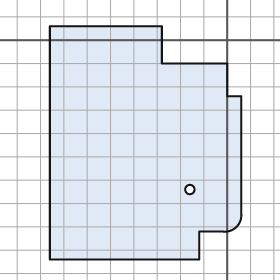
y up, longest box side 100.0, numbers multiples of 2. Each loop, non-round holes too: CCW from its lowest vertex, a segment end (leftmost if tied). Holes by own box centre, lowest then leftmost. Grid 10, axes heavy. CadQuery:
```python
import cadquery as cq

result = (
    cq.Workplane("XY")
    .moveTo(-76.0, -94.0)
    .lineTo(-12.0, -94.0)
    .lineTo(-12.0, -82.0)
    .lineTo(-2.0, -82.0)
    .threePointArc((4.0, -80.0), (6.0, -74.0))
    .lineTo(6.0, -24.0)
    .lineTo(0.0, -24.0)
    .lineTo(0.0, -10.0)
    .lineTo(-28.0, -10.0)
    .lineTo(-28.0, 6.0)
    .lineTo(-76.0, 6.0)
    .close()
    .moveTo(-16.0, -64.0)
    .circle(2.0)
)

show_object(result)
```